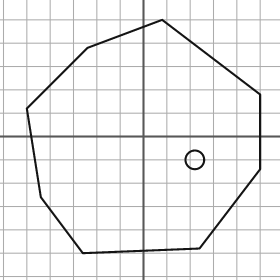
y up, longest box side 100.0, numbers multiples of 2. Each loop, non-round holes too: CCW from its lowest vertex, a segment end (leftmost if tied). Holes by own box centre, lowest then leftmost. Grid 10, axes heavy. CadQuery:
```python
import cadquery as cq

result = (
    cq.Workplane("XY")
    .moveTo(-26.0, -50.0)
    .lineTo(24.0, -48.0)
    .lineTo(50.0, -14.0)
    .lineTo(50.0, 18.0)
    .lineTo(8.0, 50.0)
    .lineTo(-24.0, 38.0)
    .lineTo(-50.0, 12.0)
    .lineTo(-44.0, -26.0)
    .close()
    .moveTo(22.0, -10.0)
    .circle(4.0)
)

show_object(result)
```